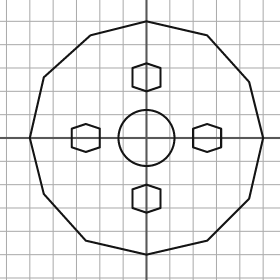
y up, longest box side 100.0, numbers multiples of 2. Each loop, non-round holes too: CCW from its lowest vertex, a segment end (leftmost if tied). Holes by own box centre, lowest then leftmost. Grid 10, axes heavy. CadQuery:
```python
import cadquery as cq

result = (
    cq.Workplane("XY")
    .moveTo(0.0, -50.0)
    .lineTo(26.0, -44.0)
    .lineTo(44.0, -26.0)
    .lineTo(50.0, 0.0)
    .lineTo(44.0, 24.0)
    .lineTo(26.0, 44.0)
    .lineTo(0.0, 50.0)
    .lineTo(-24.0, 44.0)
    .lineTo(-44.0, 26.0)
    .lineTo(-50.0, 0.0)
    .lineTo(-44.0, -24.0)
    .lineTo(-26.0, -44.0)
    .close()
    .moveTo(0.0, -32.0)
    .lineTo(6.0, -30.0)
    .lineTo(6.0, -22.0)
    .lineTo(0.0, -20.0)
    .lineTo(-6.0, -22.0)
    .lineTo(-6.0, -30.0)
    .close()
    .moveTo(-26.0, -6.0)
    .lineTo(-20.0, -4.0)
    .lineTo(-20.0, 4.0)
    .lineTo(-26.0, 6.0)
    .lineTo(-32.0, 4.0)
    .lineTo(-32.0, -4.0)
    .close()
    .moveTo(0.0, 0.0)
    .circle(12.0)
    .moveTo(26.0, -6.0)
    .lineTo(32.0, -4.0)
    .lineTo(32.0, 4.0)
    .lineTo(26.0, 6.0)
    .lineTo(20.0, 4.0)
    .lineTo(20.0, -4.0)
    .close()
    .moveTo(0.0, 20.0)
    .lineTo(6.0, 22.0)
    .lineTo(6.0, 30.0)
    .lineTo(0.0, 32.0)
    .lineTo(-6.0, 30.0)
    .lineTo(-6.0, 22.0)
    .close()
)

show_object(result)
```